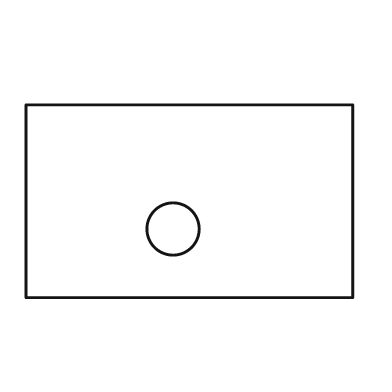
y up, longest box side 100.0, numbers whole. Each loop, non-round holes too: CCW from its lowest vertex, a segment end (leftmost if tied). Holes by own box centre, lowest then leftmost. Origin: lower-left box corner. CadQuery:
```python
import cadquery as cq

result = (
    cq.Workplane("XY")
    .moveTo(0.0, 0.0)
    .lineTo(100.0, 0.0)
    .lineTo(100.0, 59.0)
    .lineTo(0.0, 59.0)
    .close()
    .moveTo(45.0, 21.0)
    .circle(8.0)
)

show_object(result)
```